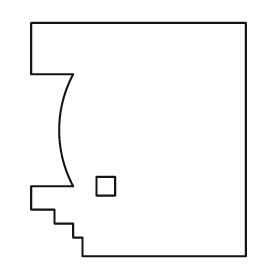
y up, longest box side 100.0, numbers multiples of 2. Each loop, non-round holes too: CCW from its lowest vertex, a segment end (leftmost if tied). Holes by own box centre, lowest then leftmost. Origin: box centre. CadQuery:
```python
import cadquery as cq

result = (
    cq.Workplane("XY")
    .moveTo(-24.0, -50.0)
    .lineTo(46.0, -50.0)
    .lineTo(46.0, 50.0)
    .lineTo(-46.0, 50.0)
    .lineTo(-46.0, 28.0)
    .lineTo(-28.0, 28.0)
    .threePointArc((-34.0, 4.0), (-28.0, -20.0))
    .lineTo(-46.0, -20.0)
    .lineTo(-46.0, -30.0)
    .lineTo(-36.0, -30.0)
    .lineTo(-36.0, -36.0)
    .lineTo(-28.0, -36.0)
    .lineTo(-28.0, -42.0)
    .lineTo(-24.0, -42.0)
    .close()
    .moveTo(-18.0, -24.0)
    .lineTo(-10.0, -24.0)
    .lineTo(-10.0, -16.0)
    .lineTo(-18.0, -16.0)
    .close()
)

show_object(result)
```